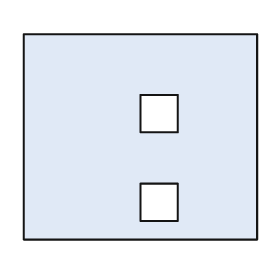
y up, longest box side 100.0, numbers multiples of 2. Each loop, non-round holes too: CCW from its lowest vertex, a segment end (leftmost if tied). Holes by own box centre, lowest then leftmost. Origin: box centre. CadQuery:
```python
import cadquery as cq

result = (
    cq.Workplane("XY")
    .moveTo(-50.0, -44.0)
    .lineTo(50.0, -44.0)
    .lineTo(50.0, 44.0)
    .lineTo(-50.0, 44.0)
    .close()
    .moveTo(0.0, -36.0)
    .lineTo(16.0, -36.0)
    .lineTo(16.0, -20.0)
    .lineTo(0.0, -20.0)
    .close()
    .moveTo(0.0, 2.0)
    .lineTo(16.0, 2.0)
    .lineTo(16.0, 18.0)
    .lineTo(0.0, 18.0)
    .close()
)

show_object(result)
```